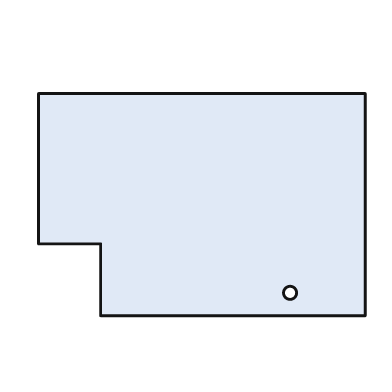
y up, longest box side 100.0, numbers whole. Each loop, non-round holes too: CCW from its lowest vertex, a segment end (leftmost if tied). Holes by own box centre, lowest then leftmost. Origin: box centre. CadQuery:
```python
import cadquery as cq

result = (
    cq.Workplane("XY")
    .moveTo(-31.0, -34.0)
    .lineTo(50.0, -34.0)
    .lineTo(50.0, 34.0)
    .lineTo(-50.0, 34.0)
    .lineTo(-50.0, -12.0)
    .lineTo(-31.0, -12.0)
    .close()
    .moveTo(27.0, -27.0)
    .circle(2.0)
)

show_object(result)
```